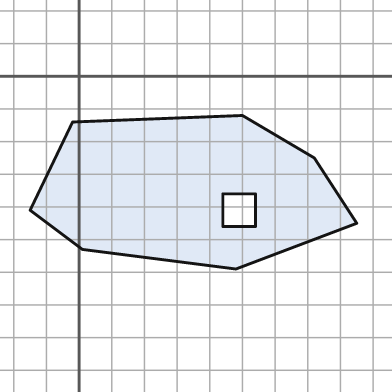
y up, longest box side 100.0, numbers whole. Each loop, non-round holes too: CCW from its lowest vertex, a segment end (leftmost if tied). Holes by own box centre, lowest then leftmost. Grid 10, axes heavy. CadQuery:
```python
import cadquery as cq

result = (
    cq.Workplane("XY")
    .moveTo(48.0, -59.0)
    .lineTo(85.0, -45.0)
    .lineTo(72.0, -25.0)
    .lineTo(50.0, -12.0)
    .lineTo(-2.0, -14.0)
    .lineTo(-15.0, -41.0)
    .lineTo(1.0, -53.0)
    .close()
    .moveTo(44.0, -46.0)
    .lineTo(54.0, -46.0)
    .lineTo(54.0, -36.0)
    .lineTo(44.0, -36.0)
    .close()
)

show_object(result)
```